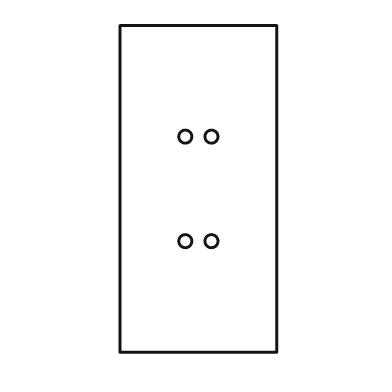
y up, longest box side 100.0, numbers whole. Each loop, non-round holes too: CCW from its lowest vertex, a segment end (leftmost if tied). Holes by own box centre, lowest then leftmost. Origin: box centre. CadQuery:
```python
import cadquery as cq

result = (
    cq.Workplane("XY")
    .moveTo(-24.0, -50.0)
    .lineTo(24.0, -50.0)
    .lineTo(24.0, 50.0)
    .lineTo(-24.0, 50.0)
    .close()
    .moveTo(-4.0, -16.0)
    .circle(2.0)
    .moveTo(4.0, -16.0)
    .circle(2.0)
    .moveTo(-4.0, 16.0)
    .circle(2.0)
    .moveTo(4.0, 16.0)
    .circle(2.0)
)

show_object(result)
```